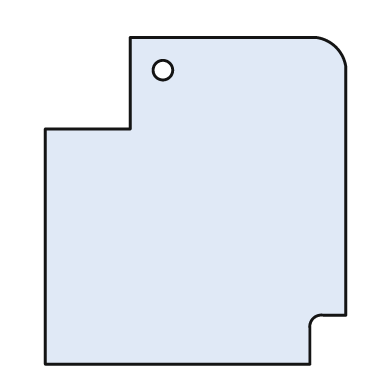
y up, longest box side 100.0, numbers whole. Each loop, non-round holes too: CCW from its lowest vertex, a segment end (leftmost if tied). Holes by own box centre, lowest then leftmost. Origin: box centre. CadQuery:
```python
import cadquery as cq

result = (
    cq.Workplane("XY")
    .moveTo(-46.0, -50.0)
    .lineTo(35.0, -50.0)
    .lineTo(35.0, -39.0)
    .threePointArc((36.0, -36.0), (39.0, -35.0))
    .lineTo(46.0, -35.0)
    .lineTo(46.0, 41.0)
    .threePointArc((43.0, 47.0), (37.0, 50.0))
    .lineTo(-20.0, 50.0)
    .lineTo(-20.0, 22.0)
    .lineTo(-46.0, 22.0)
    .close()
    .moveTo(-10.0, 40.0)
    .circle(3.0)
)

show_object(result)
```